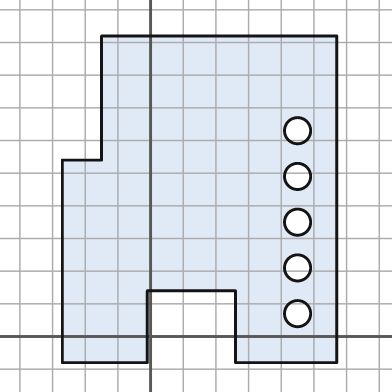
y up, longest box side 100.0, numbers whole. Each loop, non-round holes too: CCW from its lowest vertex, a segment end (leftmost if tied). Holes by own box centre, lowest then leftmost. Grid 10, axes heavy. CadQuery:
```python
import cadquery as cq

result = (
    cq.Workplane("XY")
    .moveTo(-27.0, -8.0)
    .lineTo(-1.0, -8.0)
    .lineTo(-1.0, 14.0)
    .lineTo(26.0, 14.0)
    .lineTo(26.0, -8.0)
    .lineTo(57.0, -8.0)
    .lineTo(57.0, 92.0)
    .lineTo(-15.0, 92.0)
    .lineTo(-15.0, 54.0)
    .lineTo(-27.0, 54.0)
    .close()
    .moveTo(45.0, 7.0)
    .circle(4.0)
    .moveTo(45.0, 21.0)
    .circle(4.0)
    .moveTo(45.0, 35.0)
    .circle(4.0)
    .moveTo(45.0, 49.0)
    .circle(4.0)
    .moveTo(45.0, 63.0)
    .circle(4.0)
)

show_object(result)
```